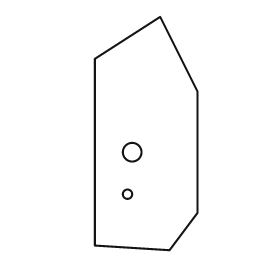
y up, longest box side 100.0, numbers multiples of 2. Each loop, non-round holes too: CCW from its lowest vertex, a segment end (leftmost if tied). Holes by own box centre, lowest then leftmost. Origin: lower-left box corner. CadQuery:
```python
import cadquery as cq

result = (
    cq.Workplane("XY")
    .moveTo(32.0, 0.0)
    .lineTo(44.0, 16.0)
    .lineTo(44.0, 68.0)
    .lineTo(28.0, 100.0)
    .lineTo(0.0, 82.0)
    .lineTo(0.0, 2.0)
    .close()
    .moveTo(14.0, 24.0)
    .circle(2.0)
    .moveTo(16.0, 42.0)
    .circle(4.0)
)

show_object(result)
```